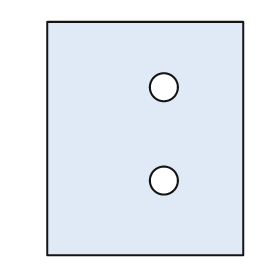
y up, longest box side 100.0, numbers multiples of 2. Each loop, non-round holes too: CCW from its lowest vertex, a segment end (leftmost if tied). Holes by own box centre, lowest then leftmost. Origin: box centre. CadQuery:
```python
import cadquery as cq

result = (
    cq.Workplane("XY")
    .moveTo(-42.0, -50.0)
    .lineTo(42.0, -50.0)
    .lineTo(42.0, 50.0)
    .lineTo(-42.0, 50.0)
    .close()
    .moveTo(8.0, -18.0)
    .circle(6.0)
    .moveTo(8.0, 22.0)
    .circle(6.0)
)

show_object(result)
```